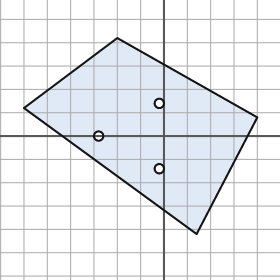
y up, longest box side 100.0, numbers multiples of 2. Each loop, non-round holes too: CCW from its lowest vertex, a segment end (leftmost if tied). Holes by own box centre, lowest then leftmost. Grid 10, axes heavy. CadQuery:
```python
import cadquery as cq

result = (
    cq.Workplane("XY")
    .moveTo(14.0, -42.0)
    .lineTo(40.0, 8.0)
    .lineTo(-20.0, 42.0)
    .lineTo(-60.0, 12.0)
    .close()
    .moveTo(-2.0, -14.0)
    .circle(2.0)
    .moveTo(-28.0, 0.0)
    .circle(2.0)
    .moveTo(-2.0, 14.0)
    .circle(2.0)
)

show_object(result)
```